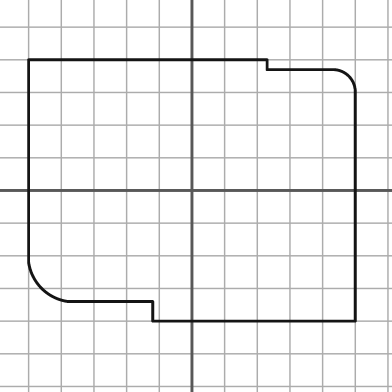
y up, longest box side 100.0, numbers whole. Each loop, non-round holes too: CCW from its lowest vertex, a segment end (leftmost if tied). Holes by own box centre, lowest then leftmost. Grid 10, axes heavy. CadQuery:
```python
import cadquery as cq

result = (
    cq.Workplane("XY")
    .moveTo(-12.0, -40.0)
    .lineTo(50.0, -40.0)
    .lineTo(50.0, 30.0)
    .threePointArc((48.0, 35.0), (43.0, 37.0))
    .lineTo(23.0, 37.0)
    .lineTo(23.0, 40.0)
    .lineTo(-50.0, 40.0)
    .lineTo(-50.0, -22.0)
    .threePointArc((-46.0, -30.0), (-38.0, -34.0))
    .lineTo(-12.0, -34.0)
    .close()
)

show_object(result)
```